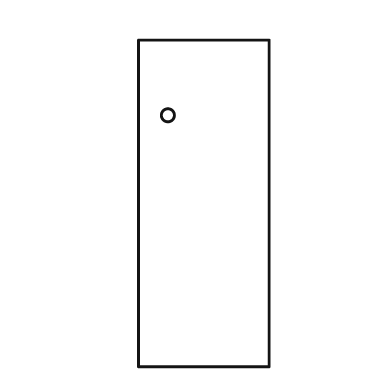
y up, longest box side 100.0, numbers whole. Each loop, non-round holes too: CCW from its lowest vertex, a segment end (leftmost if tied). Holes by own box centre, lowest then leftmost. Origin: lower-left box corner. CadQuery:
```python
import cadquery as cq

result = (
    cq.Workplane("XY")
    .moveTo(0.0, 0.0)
    .lineTo(40.0, 0.0)
    .lineTo(40.0, 100.0)
    .lineTo(0.0, 100.0)
    .close()
    .moveTo(9.0, 77.0)
    .circle(2.0)
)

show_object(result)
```